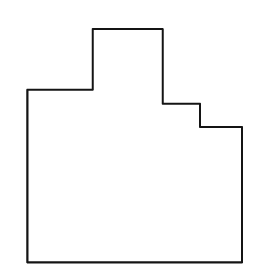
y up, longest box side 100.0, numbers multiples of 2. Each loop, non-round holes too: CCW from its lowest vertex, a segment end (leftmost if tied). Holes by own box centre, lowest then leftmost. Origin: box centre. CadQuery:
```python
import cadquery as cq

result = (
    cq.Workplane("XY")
    .moveTo(-46.0, -50.0)
    .lineTo(46.0, -50.0)
    .lineTo(46.0, 8.0)
    .lineTo(28.0, 8.0)
    .lineTo(28.0, 18.0)
    .lineTo(12.0, 18.0)
    .lineTo(12.0, 50.0)
    .lineTo(-18.0, 50.0)
    .lineTo(-18.0, 24.0)
    .lineTo(-46.0, 24.0)
    .close()
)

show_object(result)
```